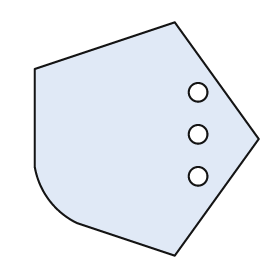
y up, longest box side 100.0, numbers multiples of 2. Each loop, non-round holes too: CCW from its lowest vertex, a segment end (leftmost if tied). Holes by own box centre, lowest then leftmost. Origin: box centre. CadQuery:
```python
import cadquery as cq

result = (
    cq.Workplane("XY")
    .moveTo(12.0, -50.0)
    .lineTo(48.0, 0.0)
    .lineTo(12.0, 50.0)
    .lineTo(-48.0, 30.0)
    .lineTo(-48.0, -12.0)
    .threePointArc((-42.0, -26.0), (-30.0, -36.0))
    .close()
    .moveTo(22.0, -16.0)
    .circle(4.0)
    .moveTo(22.0, 2.0)
    .circle(4.0)
    .moveTo(22.0, 20.0)
    .circle(4.0)
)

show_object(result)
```